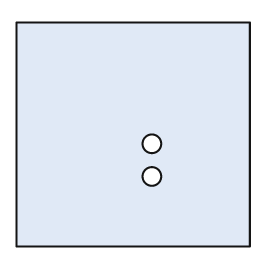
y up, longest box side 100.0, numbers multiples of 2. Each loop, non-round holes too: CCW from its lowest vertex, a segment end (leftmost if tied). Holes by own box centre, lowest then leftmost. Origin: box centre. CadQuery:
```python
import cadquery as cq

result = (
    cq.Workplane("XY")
    .moveTo(-50.0, -48.0)
    .lineTo(50.0, -48.0)
    .lineTo(50.0, 48.0)
    .lineTo(-50.0, 48.0)
    .close()
    .moveTo(8.0, -18.0)
    .circle(4.0)
    .moveTo(8.0, -4.0)
    .circle(4.0)
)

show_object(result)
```